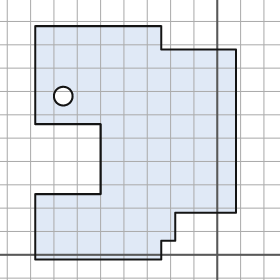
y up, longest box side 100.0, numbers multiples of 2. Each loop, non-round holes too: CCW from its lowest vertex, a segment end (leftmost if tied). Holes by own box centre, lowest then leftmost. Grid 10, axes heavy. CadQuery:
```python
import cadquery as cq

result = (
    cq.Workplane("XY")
    .moveTo(-78.0, -2.0)
    .lineTo(-24.0, -2.0)
    .lineTo(-24.0, 6.0)
    .lineTo(-18.0, 6.0)
    .lineTo(-18.0, 18.0)
    .lineTo(8.0, 18.0)
    .lineTo(8.0, 88.0)
    .lineTo(-24.0, 88.0)
    .lineTo(-24.0, 98.0)
    .lineTo(-78.0, 98.0)
    .lineTo(-78.0, 56.0)
    .lineTo(-50.0, 56.0)
    .lineTo(-50.0, 26.0)
    .lineTo(-78.0, 26.0)
    .close()
    .moveTo(-66.0, 68.0)
    .circle(4.0)
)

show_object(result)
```